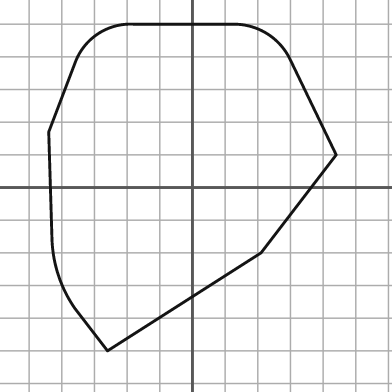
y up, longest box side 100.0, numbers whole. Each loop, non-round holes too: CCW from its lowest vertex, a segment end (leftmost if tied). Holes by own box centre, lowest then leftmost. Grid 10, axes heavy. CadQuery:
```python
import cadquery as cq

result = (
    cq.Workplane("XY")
    .moveTo(-26.0, -50.0)
    .lineTo(21.0, -20.0)
    .lineTo(44.0, 10.0)
    .lineTo(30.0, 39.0)
    .threePointArc((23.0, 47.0), (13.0, 50.0))
    .lineTo(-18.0, 50.0)
    .threePointArc((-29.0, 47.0), (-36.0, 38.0))
    .lineTo(-44.0, 17.0)
    .lineTo(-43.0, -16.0)
    .threePointArc((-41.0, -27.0), (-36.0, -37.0))
    .close()
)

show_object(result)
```